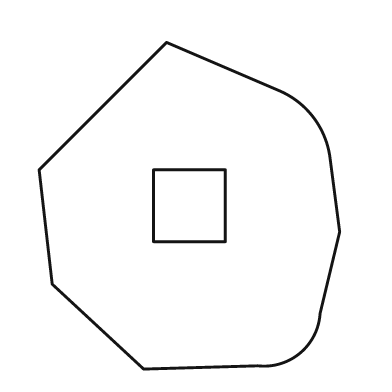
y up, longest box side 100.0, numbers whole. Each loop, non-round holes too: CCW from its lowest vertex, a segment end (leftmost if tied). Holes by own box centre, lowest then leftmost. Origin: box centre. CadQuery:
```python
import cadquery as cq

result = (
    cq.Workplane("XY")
    .moveTo(-14.0, -50.0)
    .lineTo(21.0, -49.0)
    .threePointArc((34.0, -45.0), (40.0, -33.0))
    .lineTo(46.0, -8.0)
    .lineTo(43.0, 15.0)
    .threePointArc((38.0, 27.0), (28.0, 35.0))
    .lineTo(-7.0, 50.0)
    .lineTo(-46.0, 11.0)
    .lineTo(-42.0, -24.0)
    .close()
    .moveTo(-11.0, -11.0)
    .lineTo(11.0, -11.0)
    .lineTo(11.0, 11.0)
    .lineTo(-11.0, 11.0)
    .close()
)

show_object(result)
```